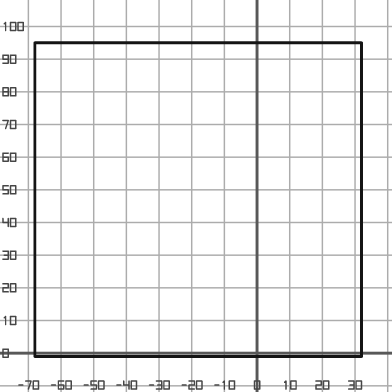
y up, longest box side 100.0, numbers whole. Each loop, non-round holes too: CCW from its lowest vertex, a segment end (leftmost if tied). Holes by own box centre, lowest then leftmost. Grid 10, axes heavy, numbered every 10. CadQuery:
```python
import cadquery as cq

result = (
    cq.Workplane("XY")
    .moveTo(-68.0, -1.0)
    .lineTo(32.0, -1.0)
    .lineTo(32.0, 95.0)
    .lineTo(-68.0, 95.0)
    .close()
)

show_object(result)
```